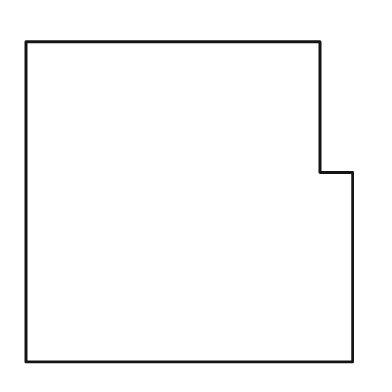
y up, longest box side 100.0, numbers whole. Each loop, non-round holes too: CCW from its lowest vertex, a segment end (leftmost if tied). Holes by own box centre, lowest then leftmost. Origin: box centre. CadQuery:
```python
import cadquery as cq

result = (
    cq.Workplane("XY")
    .moveTo(-50.0, -49.0)
    .lineTo(50.0, -49.0)
    .lineTo(50.0, 9.0)
    .lineTo(40.0, 9.0)
    .lineTo(40.0, 49.0)
    .lineTo(-50.0, 49.0)
    .close()
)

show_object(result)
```